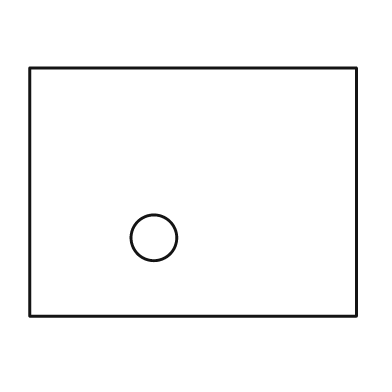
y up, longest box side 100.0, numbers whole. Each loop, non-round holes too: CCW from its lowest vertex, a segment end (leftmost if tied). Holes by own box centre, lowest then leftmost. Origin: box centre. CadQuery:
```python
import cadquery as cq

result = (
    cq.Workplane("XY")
    .moveTo(-50.0, -38.0)
    .lineTo(50.0, -38.0)
    .lineTo(50.0, 38.0)
    .lineTo(-50.0, 38.0)
    .close()
    .moveTo(-12.0, -14.0)
    .circle(7.0)
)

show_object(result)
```